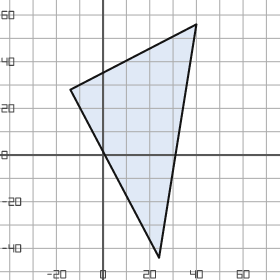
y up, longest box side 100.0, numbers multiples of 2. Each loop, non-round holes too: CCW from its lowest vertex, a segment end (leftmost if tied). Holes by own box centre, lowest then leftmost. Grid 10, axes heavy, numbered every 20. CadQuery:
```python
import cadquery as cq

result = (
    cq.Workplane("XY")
    .moveTo(24.0, -44.0)
    .lineTo(40.0, 56.0)
    .lineTo(-14.0, 28.0)
    .close()
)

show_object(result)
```